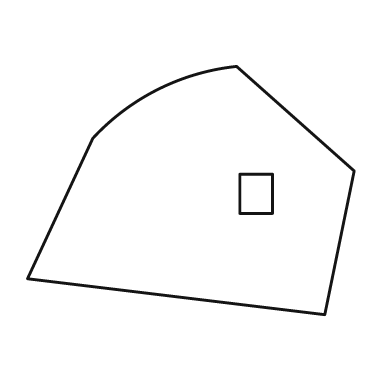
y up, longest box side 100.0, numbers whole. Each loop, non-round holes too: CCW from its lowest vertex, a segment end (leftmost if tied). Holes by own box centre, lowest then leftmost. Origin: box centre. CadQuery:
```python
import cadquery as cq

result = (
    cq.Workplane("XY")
    .moveTo(41.0, -38.0)
    .lineTo(50.0, 6.0)
    .lineTo(14.0, 38.0)
    .threePointArc((-10.0, 31.0), (-30.0, 16.0))
    .lineTo(-50.0, -27.0)
    .close()
    .moveTo(15.0, -7.0)
    .lineTo(25.0, -7.0)
    .lineTo(25.0, 5.0)
    .lineTo(15.0, 5.0)
    .close()
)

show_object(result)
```